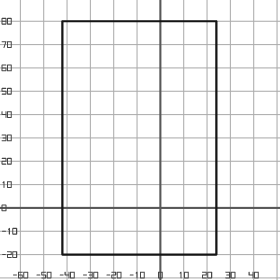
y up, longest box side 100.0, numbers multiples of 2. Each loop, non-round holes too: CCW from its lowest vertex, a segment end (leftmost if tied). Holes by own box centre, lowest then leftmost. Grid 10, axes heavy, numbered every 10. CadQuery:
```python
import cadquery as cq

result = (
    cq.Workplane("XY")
    .moveTo(-42.0, -20.0)
    .lineTo(24.0, -20.0)
    .lineTo(24.0, 80.0)
    .lineTo(-42.0, 80.0)
    .close()
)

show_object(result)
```